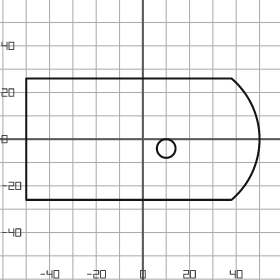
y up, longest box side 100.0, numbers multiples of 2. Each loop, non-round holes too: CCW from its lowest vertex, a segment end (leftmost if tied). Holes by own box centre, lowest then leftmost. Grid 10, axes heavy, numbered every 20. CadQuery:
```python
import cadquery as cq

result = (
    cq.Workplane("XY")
    .moveTo(-50.0, -26.0)
    .lineTo(38.0, -26.0)
    .threePointArc((50.0, 0.0), (38.0, 26.0))
    .lineTo(-50.0, 26.0)
    .close()
    .moveTo(10.0, -4.0)
    .circle(4.0)
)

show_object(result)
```